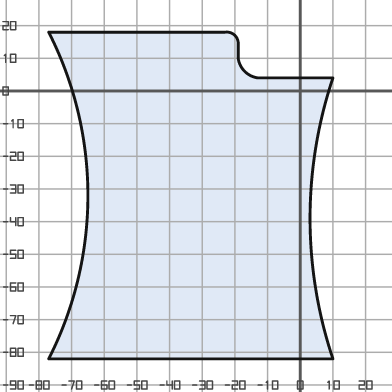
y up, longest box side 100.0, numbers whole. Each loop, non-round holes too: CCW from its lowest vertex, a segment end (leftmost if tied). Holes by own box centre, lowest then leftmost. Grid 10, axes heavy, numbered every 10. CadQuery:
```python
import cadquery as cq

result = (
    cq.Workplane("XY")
    .moveTo(-77.0, -82.0)
    .lineTo(10.0, -82.0)
    .threePointArc((3.0, -39.0), (10.0, 4.0))
    .lineTo(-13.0, 4.0)
    .threePointArc((-17.0, 6.0), (-19.0, 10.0))
    .lineTo(-19.0, 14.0)
    .threePointArc((-20.0, 17.0), (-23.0, 18.0))
    .lineTo(-77.0, 18.0)
    .threePointArc((-65.0, -32.0), (-77.0, -82.0))
    .close()
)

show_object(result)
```